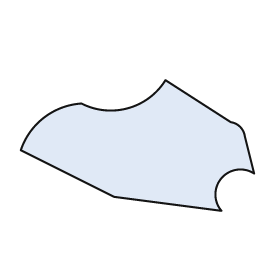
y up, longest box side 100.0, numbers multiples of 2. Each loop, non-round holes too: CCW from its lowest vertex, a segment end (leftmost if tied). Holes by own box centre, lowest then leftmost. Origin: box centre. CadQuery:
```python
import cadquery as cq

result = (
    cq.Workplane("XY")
    .moveTo(36.0, -28.0)
    .threePointArc((36.0, -14.0), (50.0, -12.0))
    .lineTo(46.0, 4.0)
    .threePointArc((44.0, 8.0), (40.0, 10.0))
    .lineTo(12.0, 28.0)
    .threePointArc((-4.0, 16.0), (-24.0, 18.0))
    .threePointArc((-40.0, 12.0), (-50.0, -2.0))
    .lineTo(-10.0, -22.0)
    .close()
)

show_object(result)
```